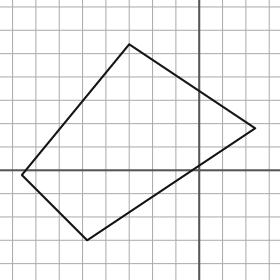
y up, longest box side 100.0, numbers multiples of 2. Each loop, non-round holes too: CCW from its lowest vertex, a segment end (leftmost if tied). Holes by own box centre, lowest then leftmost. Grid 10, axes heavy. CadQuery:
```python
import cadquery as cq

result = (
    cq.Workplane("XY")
    .moveTo(-48.0, -30.0)
    .lineTo(24.0, 18.0)
    .lineTo(-30.0, 54.0)
    .lineTo(-76.0, -2.0)
    .close()
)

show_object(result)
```